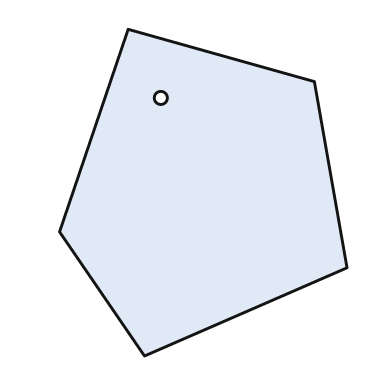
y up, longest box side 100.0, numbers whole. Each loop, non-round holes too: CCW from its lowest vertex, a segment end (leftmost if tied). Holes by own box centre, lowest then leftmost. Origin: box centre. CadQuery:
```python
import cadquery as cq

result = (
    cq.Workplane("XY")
    .moveTo(-18.0, -50.0)
    .lineTo(44.0, -23.0)
    .lineTo(34.0, 34.0)
    .lineTo(-23.0, 50.0)
    .lineTo(-44.0, -12.0)
    .close()
    .moveTo(-13.0, 29.0)
    .circle(2.0)
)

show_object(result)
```